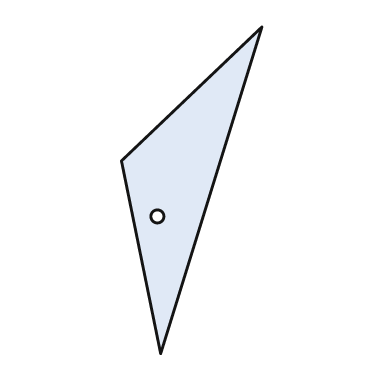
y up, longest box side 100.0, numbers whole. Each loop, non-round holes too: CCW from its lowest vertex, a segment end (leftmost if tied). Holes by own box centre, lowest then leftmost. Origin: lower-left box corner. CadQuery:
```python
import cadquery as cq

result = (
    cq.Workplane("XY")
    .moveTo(12.0, 0.0)
    .lineTo(43.0, 100.0)
    .lineTo(0.0, 59.0)
    .close()
    .moveTo(11.0, 42.0)
    .circle(2.0)
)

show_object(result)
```